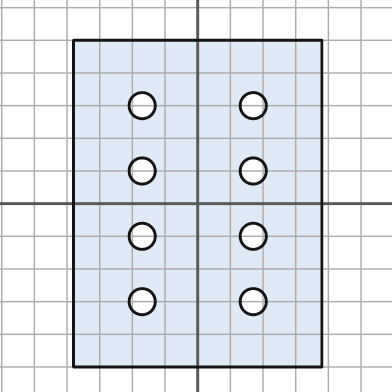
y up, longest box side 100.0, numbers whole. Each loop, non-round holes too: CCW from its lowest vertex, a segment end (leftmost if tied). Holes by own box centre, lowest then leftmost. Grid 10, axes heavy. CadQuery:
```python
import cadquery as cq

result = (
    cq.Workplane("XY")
    .moveTo(-38.0, -50.0)
    .lineTo(38.0, -50.0)
    .lineTo(38.0, 50.0)
    .lineTo(-38.0, 50.0)
    .close()
    .moveTo(-17.0, -30.0)
    .circle(4.0)
    .moveTo(17.0, -30.0)
    .circle(4.0)
    .moveTo(-17.0, -10.0)
    .circle(4.0)
    .moveTo(17.0, -10.0)
    .circle(4.0)
    .moveTo(-17.0, 10.0)
    .circle(4.0)
    .moveTo(17.0, 10.0)
    .circle(4.0)
    .moveTo(-17.0, 30.0)
    .circle(4.0)
    .moveTo(17.0, 30.0)
    .circle(4.0)
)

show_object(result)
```